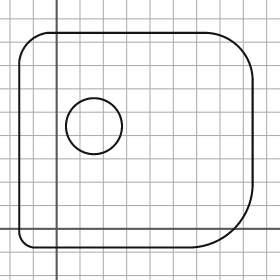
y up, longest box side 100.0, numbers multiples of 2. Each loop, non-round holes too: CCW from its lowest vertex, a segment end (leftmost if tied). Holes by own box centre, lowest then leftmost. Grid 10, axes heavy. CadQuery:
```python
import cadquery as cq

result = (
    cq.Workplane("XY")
    .moveTo(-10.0, -8.0)
    .lineTo(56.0, -8.0)
    .threePointArc((76.0, 0.0), (84.0, 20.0))
    .lineTo(84.0, 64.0)
    .threePointArc((78.0, 78.0), (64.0, 84.0))
    .lineTo(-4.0, 84.0)
    .threePointArc((-12.0, 80.0), (-16.0, 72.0))
    .lineTo(-16.0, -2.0)
    .threePointArc((-14.0, -6.0), (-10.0, -8.0))
    .close()
    .moveTo(16.0, 44.0)
    .circle(12.0)
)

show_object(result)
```